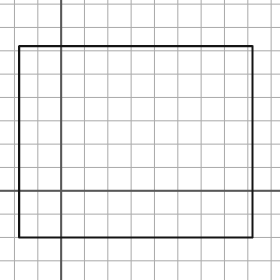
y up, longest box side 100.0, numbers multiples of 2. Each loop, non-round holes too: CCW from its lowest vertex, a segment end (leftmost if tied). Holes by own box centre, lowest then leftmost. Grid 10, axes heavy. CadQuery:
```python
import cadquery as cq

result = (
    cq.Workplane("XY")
    .moveTo(-18.0, -20.0)
    .lineTo(82.0, -20.0)
    .lineTo(82.0, 62.0)
    .lineTo(-18.0, 62.0)
    .close()
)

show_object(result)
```